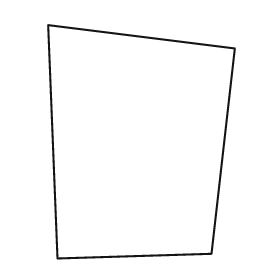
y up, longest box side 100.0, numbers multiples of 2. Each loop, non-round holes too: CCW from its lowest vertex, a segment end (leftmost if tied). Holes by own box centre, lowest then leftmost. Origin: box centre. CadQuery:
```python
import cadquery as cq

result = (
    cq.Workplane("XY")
    .moveTo(-36.0, -50.0)
    .lineTo(30.0, -48.0)
    .lineTo(40.0, 40.0)
    .lineTo(-40.0, 50.0)
    .close()
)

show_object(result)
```